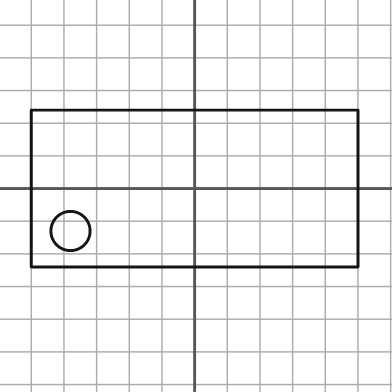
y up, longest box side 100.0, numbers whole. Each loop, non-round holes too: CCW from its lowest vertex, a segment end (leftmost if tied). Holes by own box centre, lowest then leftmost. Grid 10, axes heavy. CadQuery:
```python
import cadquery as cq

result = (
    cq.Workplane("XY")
    .moveTo(-50.0, -24.0)
    .lineTo(50.0, -24.0)
    .lineTo(50.0, 24.0)
    .lineTo(-50.0, 24.0)
    .close()
    .moveTo(-38.0, -13.0)
    .circle(6.0)
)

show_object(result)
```